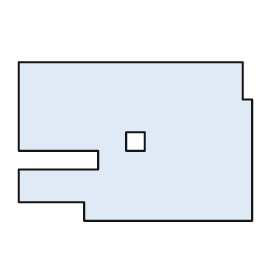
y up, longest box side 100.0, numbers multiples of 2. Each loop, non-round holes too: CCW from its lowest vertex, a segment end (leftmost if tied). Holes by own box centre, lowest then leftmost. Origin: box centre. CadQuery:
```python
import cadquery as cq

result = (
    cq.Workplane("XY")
    .moveTo(-22.0, -34.0)
    .lineTo(50.0, -34.0)
    .lineTo(50.0, 18.0)
    .lineTo(46.0, 18.0)
    .lineTo(46.0, 34.0)
    .lineTo(-50.0, 34.0)
    .lineTo(-50.0, -4.0)
    .lineTo(-16.0, -4.0)
    .lineTo(-16.0, -12.0)
    .lineTo(-50.0, -12.0)
    .lineTo(-50.0, -26.0)
    .lineTo(-22.0, -26.0)
    .close()
    .moveTo(-4.0, -4.0)
    .lineTo(4.0, -4.0)
    .lineTo(4.0, 4.0)
    .lineTo(-4.0, 4.0)
    .close()
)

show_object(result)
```